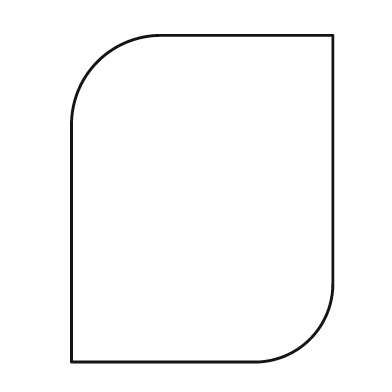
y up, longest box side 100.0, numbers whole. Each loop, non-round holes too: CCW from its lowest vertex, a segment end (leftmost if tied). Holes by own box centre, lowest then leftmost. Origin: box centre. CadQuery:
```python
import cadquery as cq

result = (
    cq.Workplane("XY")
    .moveTo(-40.0, -50.0)
    .lineTo(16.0, -50.0)
    .threePointArc((33.0, -43.0), (40.0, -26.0))
    .lineTo(40.0, 50.0)
    .lineTo(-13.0, 50.0)
    .threePointArc((-32.0, 42.0), (-40.0, 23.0))
    .close()
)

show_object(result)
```